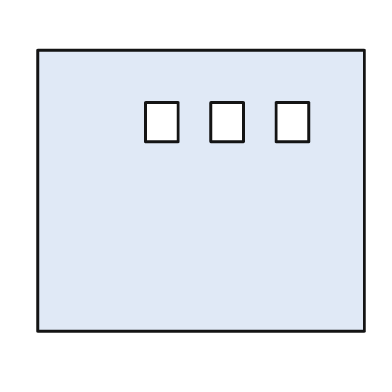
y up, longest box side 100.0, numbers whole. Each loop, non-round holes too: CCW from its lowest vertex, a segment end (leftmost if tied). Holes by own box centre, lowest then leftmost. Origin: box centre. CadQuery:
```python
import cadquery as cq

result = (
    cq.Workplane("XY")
    .moveTo(-50.0, -43.0)
    .lineTo(50.0, -43.0)
    .lineTo(50.0, 43.0)
    .lineTo(-50.0, 43.0)
    .close()
    .moveTo(-17.0, 15.0)
    .lineTo(-7.0, 15.0)
    .lineTo(-7.0, 27.0)
    .lineTo(-17.0, 27.0)
    .close()
    .moveTo(3.0, 15.0)
    .lineTo(13.0, 15.0)
    .lineTo(13.0, 27.0)
    .lineTo(3.0, 27.0)
    .close()
    .moveTo(23.0, 15.0)
    .lineTo(33.0, 15.0)
    .lineTo(33.0, 27.0)
    .lineTo(23.0, 27.0)
    .close()
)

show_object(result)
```